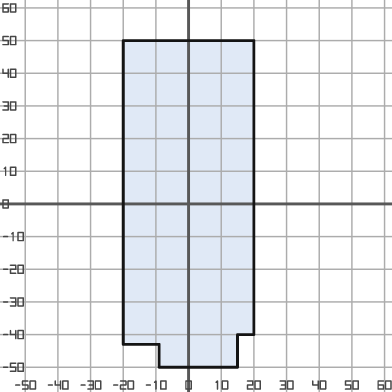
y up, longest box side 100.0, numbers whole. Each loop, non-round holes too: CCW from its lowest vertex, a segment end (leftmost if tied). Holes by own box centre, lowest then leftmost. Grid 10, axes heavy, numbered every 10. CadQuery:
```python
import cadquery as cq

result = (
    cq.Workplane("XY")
    .moveTo(-9.0, -50.0)
    .lineTo(15.0, -50.0)
    .lineTo(15.0, -40.0)
    .lineTo(20.0, -40.0)
    .lineTo(20.0, 50.0)
    .lineTo(-20.0, 50.0)
    .lineTo(-20.0, -43.0)
    .lineTo(-9.0, -43.0)
    .close()
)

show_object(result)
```